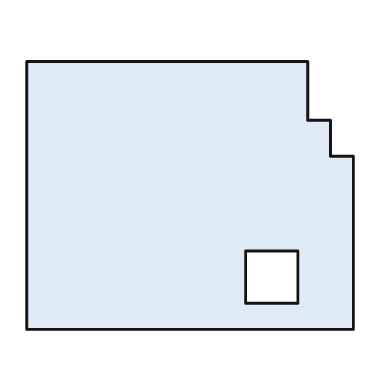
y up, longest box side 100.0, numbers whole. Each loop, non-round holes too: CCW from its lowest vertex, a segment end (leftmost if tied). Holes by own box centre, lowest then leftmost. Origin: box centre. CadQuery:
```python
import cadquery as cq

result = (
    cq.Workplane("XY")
    .moveTo(-50.0, -41.0)
    .lineTo(50.0, -41.0)
    .lineTo(50.0, 12.0)
    .lineTo(43.0, 12.0)
    .lineTo(43.0, 23.0)
    .lineTo(36.0, 23.0)
    .lineTo(36.0, 41.0)
    .lineTo(-50.0, 41.0)
    .close()
    .moveTo(17.0, -33.0)
    .lineTo(33.0, -33.0)
    .lineTo(33.0, -17.0)
    .lineTo(17.0, -17.0)
    .close()
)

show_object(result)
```